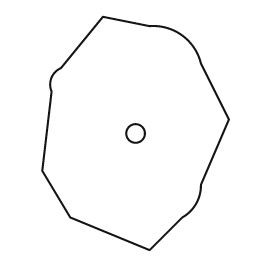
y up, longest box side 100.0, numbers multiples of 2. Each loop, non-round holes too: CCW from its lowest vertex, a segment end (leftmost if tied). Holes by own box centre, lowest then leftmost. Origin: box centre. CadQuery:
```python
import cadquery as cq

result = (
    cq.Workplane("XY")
    .moveTo(6.0, -50.0)
    .lineTo(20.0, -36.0)
    .threePointArc((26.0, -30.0), (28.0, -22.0))
    .lineTo(40.0, 6.0)
    .lineTo(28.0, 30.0)
    .threePointArc((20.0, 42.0), (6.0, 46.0))
    .lineTo(-14.0, 50.0)
    .lineTo(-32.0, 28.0)
    .threePointArc((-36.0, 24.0), (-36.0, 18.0))
    .lineTo(-40.0, -16.0)
    .lineTo(-28.0, -36.0)
    .close()
    .moveTo(0.0, 0.0)
    .circle(4.0)
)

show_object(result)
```